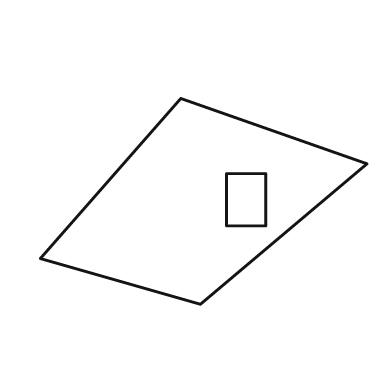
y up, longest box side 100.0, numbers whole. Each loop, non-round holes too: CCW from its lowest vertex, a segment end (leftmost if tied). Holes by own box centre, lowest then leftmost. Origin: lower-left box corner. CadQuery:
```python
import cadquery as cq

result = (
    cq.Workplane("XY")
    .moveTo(49.0, 0.0)
    .lineTo(100.0, 43.0)
    .lineTo(43.0, 63.0)
    .lineTo(0.0, 14.0)
    .close()
    .moveTo(57.0, 24.0)
    .lineTo(69.0, 24.0)
    .lineTo(69.0, 40.0)
    .lineTo(57.0, 40.0)
    .close()
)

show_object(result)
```